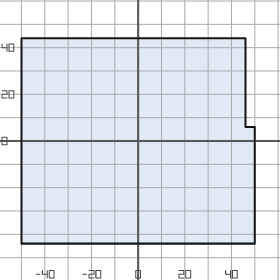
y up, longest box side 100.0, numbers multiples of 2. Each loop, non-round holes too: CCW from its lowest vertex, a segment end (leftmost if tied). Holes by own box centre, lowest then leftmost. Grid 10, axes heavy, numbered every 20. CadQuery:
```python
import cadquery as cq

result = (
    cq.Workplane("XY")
    .moveTo(-50.0, -44.0)
    .lineTo(50.0, -44.0)
    .lineTo(50.0, 6.0)
    .lineTo(46.0, 6.0)
    .lineTo(46.0, 44.0)
    .lineTo(-50.0, 44.0)
    .close()
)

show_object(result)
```